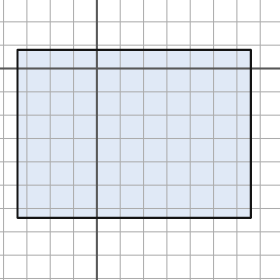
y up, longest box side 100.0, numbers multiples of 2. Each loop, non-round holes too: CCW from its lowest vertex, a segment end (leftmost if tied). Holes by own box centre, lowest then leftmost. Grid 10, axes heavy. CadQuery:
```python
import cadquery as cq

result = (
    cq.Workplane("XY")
    .moveTo(-34.0, -64.0)
    .lineTo(66.0, -64.0)
    .lineTo(66.0, 8.0)
    .lineTo(-34.0, 8.0)
    .close()
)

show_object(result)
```